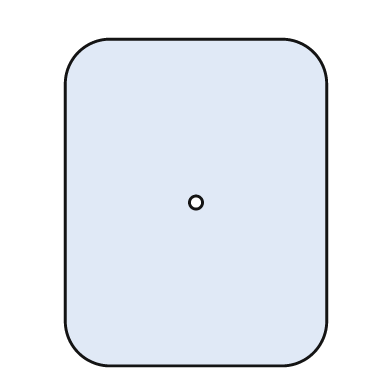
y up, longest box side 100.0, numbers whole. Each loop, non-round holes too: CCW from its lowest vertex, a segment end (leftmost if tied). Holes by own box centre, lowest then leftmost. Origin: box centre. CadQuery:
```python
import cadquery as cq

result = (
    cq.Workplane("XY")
    .moveTo(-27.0, -50.0)
    .lineTo(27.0, -50.0)
    .threePointArc((36.0, -46.0), (40.0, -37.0))
    .lineTo(40.0, 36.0)
    .threePointArc((36.0, 46.0), (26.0, 50.0))
    .lineTo(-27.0, 50.0)
    .threePointArc((-36.0, 46.0), (-40.0, 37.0))
    .lineTo(-40.0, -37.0)
    .threePointArc((-36.0, -46.0), (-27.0, -50.0))
    .close()
    .moveTo(0.0, 0.0)
    .circle(2.0)
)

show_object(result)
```